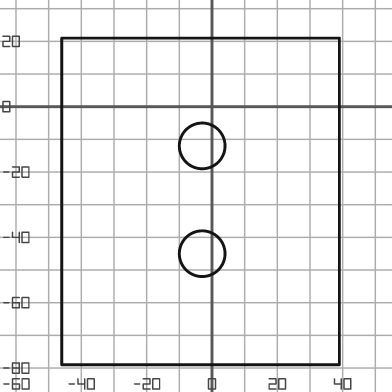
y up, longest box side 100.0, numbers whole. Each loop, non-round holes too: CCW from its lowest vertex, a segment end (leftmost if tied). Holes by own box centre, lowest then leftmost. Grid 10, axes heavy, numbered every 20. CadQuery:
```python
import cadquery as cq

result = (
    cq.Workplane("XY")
    .moveTo(-46.0, -79.0)
    .lineTo(39.0, -79.0)
    .lineTo(39.0, 21.0)
    .lineTo(-46.0, 21.0)
    .close()
    .moveTo(-3.0, -45.0)
    .circle(7.0)
    .moveTo(-3.0, -12.0)
    .circle(7.0)
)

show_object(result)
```